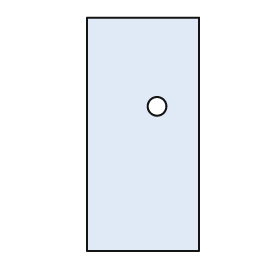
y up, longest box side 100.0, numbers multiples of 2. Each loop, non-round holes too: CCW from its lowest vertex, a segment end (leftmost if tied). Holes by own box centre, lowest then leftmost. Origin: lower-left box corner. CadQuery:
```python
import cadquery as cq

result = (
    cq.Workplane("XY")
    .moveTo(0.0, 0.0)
    .lineTo(48.0, 0.0)
    .lineTo(48.0, 100.0)
    .lineTo(0.0, 100.0)
    .close()
    .moveTo(30.0, 62.0)
    .circle(4.0)
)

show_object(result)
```